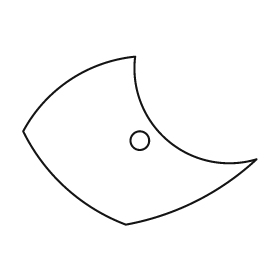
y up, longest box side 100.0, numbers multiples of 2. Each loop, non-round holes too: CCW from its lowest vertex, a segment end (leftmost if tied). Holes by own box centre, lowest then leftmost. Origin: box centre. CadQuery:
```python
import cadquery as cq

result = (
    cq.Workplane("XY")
    .moveTo(-6.0, -36.0)
    .threePointArc((24.0, -26.0), (50.0, -8.0))
    .threePointArc((12.0, 0.0), (-2.0, 36.0))
    .threePointArc((-30.0, 26.0), (-50.0, 4.0))
    .threePointArc((-32.0, -20.0), (-6.0, -36.0))
    .close()
    .moveTo(0.0, 0.0)
    .circle(4.0)
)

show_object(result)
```